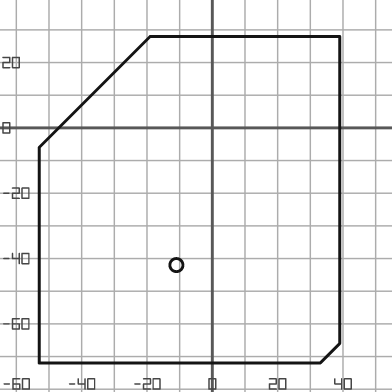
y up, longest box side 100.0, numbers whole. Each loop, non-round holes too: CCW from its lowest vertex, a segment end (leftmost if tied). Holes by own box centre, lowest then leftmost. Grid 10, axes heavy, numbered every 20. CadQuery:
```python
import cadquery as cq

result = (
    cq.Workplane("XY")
    .moveTo(-53.0, -72.0)
    .lineTo(33.0, -72.0)
    .lineTo(39.0, -66.0)
    .lineTo(39.0, 28.0)
    .lineTo(-19.0, 28.0)
    .lineTo(-53.0, -6.0)
    .close()
    .moveTo(-11.0, -42.0)
    .circle(2.0)
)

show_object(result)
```